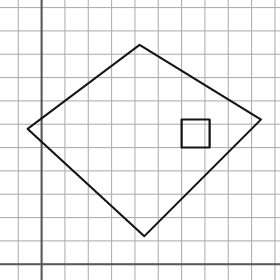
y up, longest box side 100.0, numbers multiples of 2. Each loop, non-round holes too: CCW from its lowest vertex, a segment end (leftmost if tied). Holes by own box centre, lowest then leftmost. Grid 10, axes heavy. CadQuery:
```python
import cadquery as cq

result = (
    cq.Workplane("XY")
    .moveTo(44.0, 12.0)
    .lineTo(94.0, 62.0)
    .lineTo(42.0, 94.0)
    .lineTo(-6.0, 58.0)
    .close()
    .moveTo(60.0, 50.0)
    .lineTo(72.0, 50.0)
    .lineTo(72.0, 62.0)
    .lineTo(60.0, 62.0)
    .close()
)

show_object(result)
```